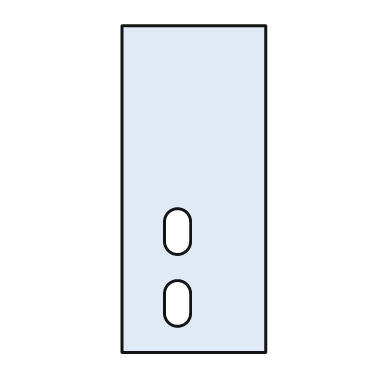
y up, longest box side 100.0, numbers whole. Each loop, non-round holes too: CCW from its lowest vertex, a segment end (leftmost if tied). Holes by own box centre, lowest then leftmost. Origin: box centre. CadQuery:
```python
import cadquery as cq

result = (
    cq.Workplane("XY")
    .moveTo(-22.0, -50.0)
    .lineTo(22.0, -50.0)
    .lineTo(22.0, 50.0)
    .lineTo(-22.0, 50.0)
    .close()
    .moveTo(-9.0, -38.0)
    .threePointArc((-5.0, -42.0), (-1.0, -38.0))
    .lineTo(-1.0, -32.0)
    .threePointArc((-5.0, -28.0), (-9.0, -32.0))
    .close()
    .moveTo(-9.0, -16.0)
    .threePointArc((-5.0, -20.0), (-1.0, -16.0))
    .lineTo(-1.0, -10.0)
    .threePointArc((-5.0, -6.0), (-9.0, -10.0))
    .close()
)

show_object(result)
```